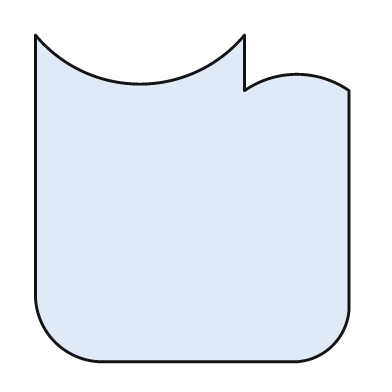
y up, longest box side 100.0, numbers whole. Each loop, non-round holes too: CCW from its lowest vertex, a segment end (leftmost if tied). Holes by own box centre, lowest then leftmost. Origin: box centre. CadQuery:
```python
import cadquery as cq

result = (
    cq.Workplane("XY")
    .moveTo(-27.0, -50.0)
    .lineTo(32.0, -50.0)
    .threePointArc((43.0, -45.0), (48.0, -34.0))
    .lineTo(48.0, 33.0)
    .threePointArc((32.0, 38.0), (16.0, 33.0))
    .lineTo(16.0, 50.0)
    .threePointArc((-16.0, 35.0), (-48.0, 50.0))
    .lineTo(-48.0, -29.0)
    .threePointArc((-42.0, -44.0), (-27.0, -50.0))
    .close()
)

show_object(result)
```